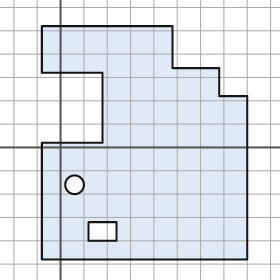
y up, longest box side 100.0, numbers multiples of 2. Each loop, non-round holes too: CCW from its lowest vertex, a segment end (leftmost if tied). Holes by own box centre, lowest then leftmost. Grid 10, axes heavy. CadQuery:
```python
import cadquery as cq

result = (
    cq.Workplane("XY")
    .moveTo(-8.0, -48.0)
    .lineTo(80.0, -48.0)
    .lineTo(80.0, 22.0)
    .lineTo(68.0, 22.0)
    .lineTo(68.0, 34.0)
    .lineTo(48.0, 34.0)
    .lineTo(48.0, 52.0)
    .lineTo(-8.0, 52.0)
    .lineTo(-8.0, 32.0)
    .lineTo(18.0, 32.0)
    .lineTo(18.0, 2.0)
    .lineTo(-8.0, 2.0)
    .close()
    .moveTo(12.0, -40.0)
    .lineTo(24.0, -40.0)
    .lineTo(24.0, -32.0)
    .lineTo(12.0, -32.0)
    .close()
    .moveTo(6.0, -16.0)
    .circle(4.0)
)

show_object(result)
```